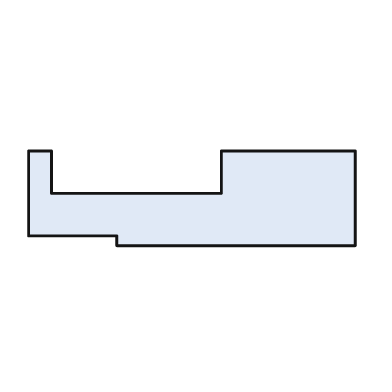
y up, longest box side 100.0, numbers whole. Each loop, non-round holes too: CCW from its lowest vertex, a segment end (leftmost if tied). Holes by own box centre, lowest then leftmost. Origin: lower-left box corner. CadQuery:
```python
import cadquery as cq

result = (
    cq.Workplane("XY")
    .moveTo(27.0, 0.0)
    .lineTo(100.0, 0.0)
    .lineTo(100.0, 29.0)
    .lineTo(59.0, 29.0)
    .lineTo(59.0, 16.0)
    .lineTo(7.0, 16.0)
    .lineTo(7.0, 29.0)
    .lineTo(0.0, 29.0)
    .lineTo(0.0, 3.0)
    .lineTo(27.0, 3.0)
    .close()
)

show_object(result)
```